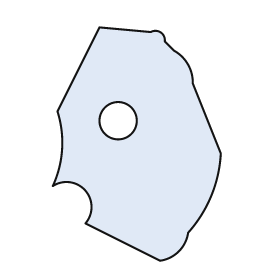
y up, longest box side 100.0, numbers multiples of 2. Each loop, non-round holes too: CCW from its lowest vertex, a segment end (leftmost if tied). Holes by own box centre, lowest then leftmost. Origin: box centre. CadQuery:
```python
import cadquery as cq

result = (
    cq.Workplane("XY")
    .moveTo(10.0, -50.0)
    .threePointArc((18.0, -46.0), (22.0, -38.0))
    .threePointArc((32.0, -22.0), (36.0, -4.0))
    .lineTo(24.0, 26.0)
    .threePointArc((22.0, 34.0), (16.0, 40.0))
    .lineTo(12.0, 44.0)
    .threePointArc((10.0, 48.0), (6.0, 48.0))
    .lineTo(-16.0, 50.0)
    .lineTo(-34.0, 14.0)
    .threePointArc((-32.0, -2.0), (-36.0, -18.0))
    .threePointArc((-22.0, -20.0), (-22.0, -34.0))
    .close()
    .moveTo(-8.0, 10.0)
    .circle(8.0)
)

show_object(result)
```